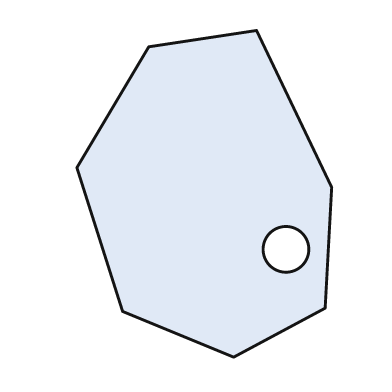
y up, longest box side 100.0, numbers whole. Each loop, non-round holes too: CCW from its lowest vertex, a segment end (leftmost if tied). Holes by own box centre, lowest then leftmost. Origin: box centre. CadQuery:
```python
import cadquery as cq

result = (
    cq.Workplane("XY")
    .moveTo(9.0, -50.0)
    .lineTo(37.0, -35.0)
    .lineTo(39.0, 2.0)
    .lineTo(16.0, 50.0)
    .lineTo(-17.0, 45.0)
    .lineTo(-39.0, 8.0)
    .lineTo(-25.0, -36.0)
    .close()
    .moveTo(25.0, -17.0)
    .circle(7.0)
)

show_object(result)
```